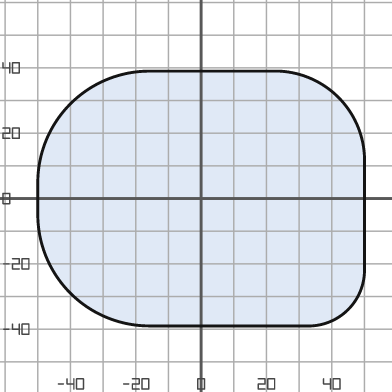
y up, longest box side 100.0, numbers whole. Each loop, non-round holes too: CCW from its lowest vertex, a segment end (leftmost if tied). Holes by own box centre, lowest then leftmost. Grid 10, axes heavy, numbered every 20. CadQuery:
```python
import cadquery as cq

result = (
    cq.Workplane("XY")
    .moveTo(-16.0, -39.0)
    .lineTo(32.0, -39.0)
    .threePointArc((45.0, -34.0), (50.0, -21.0))
    .lineTo(50.0, 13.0)
    .threePointArc((42.0, 31.0), (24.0, 39.0))
    .lineTo(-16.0, 39.0)
    .threePointArc((-40.0, 29.0), (-50.0, 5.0))
    .lineTo(-50.0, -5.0)
    .threePointArc((-40.0, -29.0), (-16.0, -39.0))
    .close()
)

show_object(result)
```